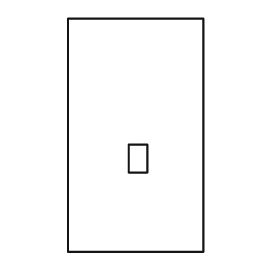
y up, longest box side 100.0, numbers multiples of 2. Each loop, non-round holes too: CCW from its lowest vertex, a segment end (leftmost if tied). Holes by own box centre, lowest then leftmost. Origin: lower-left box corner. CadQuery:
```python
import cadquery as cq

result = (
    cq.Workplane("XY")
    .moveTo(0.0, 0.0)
    .lineTo(58.0, 0.0)
    .lineTo(58.0, 100.0)
    .lineTo(0.0, 100.0)
    .close()
    .moveTo(26.0, 34.0)
    .lineTo(34.0, 34.0)
    .lineTo(34.0, 46.0)
    .lineTo(26.0, 46.0)
    .close()
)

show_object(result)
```